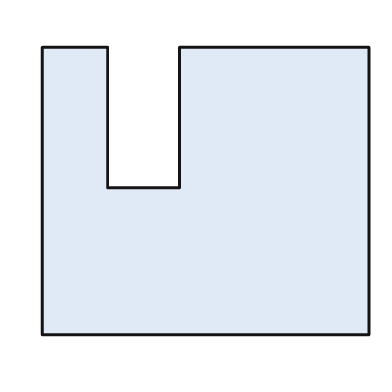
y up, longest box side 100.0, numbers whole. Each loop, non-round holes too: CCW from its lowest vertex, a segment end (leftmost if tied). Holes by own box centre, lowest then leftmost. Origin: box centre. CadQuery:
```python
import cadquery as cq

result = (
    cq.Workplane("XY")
    .moveTo(-50.0, -44.0)
    .lineTo(50.0, -44.0)
    .lineTo(50.0, 44.0)
    .lineTo(-8.0, 44.0)
    .lineTo(-8.0, 1.0)
    .lineTo(-30.0, 1.0)
    .lineTo(-30.0, 44.0)
    .lineTo(-50.0, 44.0)
    .close()
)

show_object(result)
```